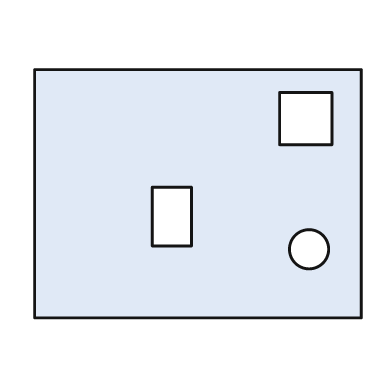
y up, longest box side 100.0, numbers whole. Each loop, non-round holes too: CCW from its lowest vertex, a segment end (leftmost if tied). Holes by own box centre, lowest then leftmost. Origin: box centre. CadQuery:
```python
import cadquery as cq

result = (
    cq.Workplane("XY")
    .moveTo(-50.0, -38.0)
    .lineTo(50.0, -38.0)
    .lineTo(50.0, 38.0)
    .lineTo(-50.0, 38.0)
    .close()
    .moveTo(34.0, -17.0)
    .circle(6.0)
    .moveTo(-14.0, -16.0)
    .lineTo(-2.0, -16.0)
    .lineTo(-2.0, 2.0)
    .lineTo(-14.0, 2.0)
    .close()
    .moveTo(25.0, 15.0)
    .lineTo(41.0, 15.0)
    .lineTo(41.0, 31.0)
    .lineTo(25.0, 31.0)
    .close()
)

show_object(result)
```